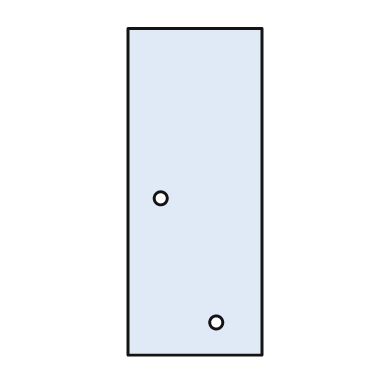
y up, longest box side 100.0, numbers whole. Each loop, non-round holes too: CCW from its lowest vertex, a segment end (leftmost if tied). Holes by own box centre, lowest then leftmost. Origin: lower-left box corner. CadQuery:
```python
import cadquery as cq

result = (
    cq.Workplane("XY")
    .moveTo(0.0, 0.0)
    .lineTo(41.0, 0.0)
    .lineTo(41.0, 100.0)
    .lineTo(0.0, 100.0)
    .close()
    .moveTo(27.0, 10.0)
    .circle(2.0)
    .moveTo(10.0, 48.0)
    .circle(2.0)
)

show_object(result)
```